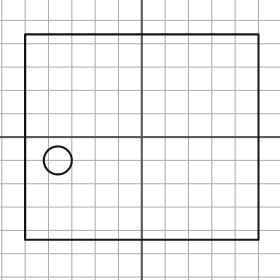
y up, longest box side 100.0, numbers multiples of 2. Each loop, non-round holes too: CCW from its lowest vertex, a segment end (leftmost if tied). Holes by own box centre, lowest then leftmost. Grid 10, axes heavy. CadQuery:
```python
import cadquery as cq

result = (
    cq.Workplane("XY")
    .moveTo(-50.0, -44.0)
    .lineTo(50.0, -44.0)
    .lineTo(50.0, 44.0)
    .lineTo(-50.0, 44.0)
    .close()
    .moveTo(-36.0, -10.0)
    .circle(6.0)
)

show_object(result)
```